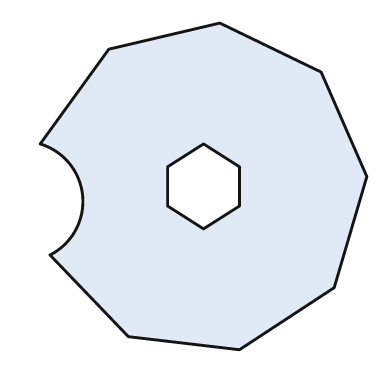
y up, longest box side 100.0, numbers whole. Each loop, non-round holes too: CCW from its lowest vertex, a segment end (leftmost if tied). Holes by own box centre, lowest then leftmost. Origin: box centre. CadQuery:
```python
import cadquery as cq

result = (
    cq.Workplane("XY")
    .moveTo(11.0, -50.0)
    .lineTo(40.0, -31.0)
    .lineTo(50.0, 3.0)
    .lineTo(36.0, 35.0)
    .lineTo(5.0, 50.0)
    .lineTo(-29.0, 42.0)
    .lineTo(-50.0, 13.0)
    .threePointArc((-37.0, -3.0), (-47.0, -21.0))
    .lineTo(-23.0, -46.0)
    .close()
    .moveTo(0.0, -13.0)
    .lineTo(11.0, -6.0)
    .lineTo(11.0, 6.0)
    .lineTo(0.0, 13.0)
    .lineTo(-11.0, 6.0)
    .lineTo(-11.0, -6.0)
    .close()
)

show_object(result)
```